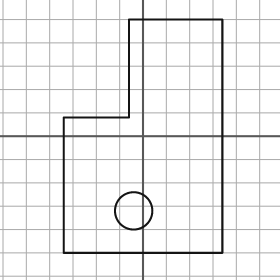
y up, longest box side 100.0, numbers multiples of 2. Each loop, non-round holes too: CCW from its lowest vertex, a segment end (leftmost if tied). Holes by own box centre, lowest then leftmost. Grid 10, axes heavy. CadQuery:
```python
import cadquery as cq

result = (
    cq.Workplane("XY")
    .moveTo(-34.0, -50.0)
    .lineTo(34.0, -50.0)
    .lineTo(34.0, 50.0)
    .lineTo(-6.0, 50.0)
    .lineTo(-6.0, 8.0)
    .lineTo(-34.0, 8.0)
    .close()
    .moveTo(-4.0, -32.0)
    .circle(8.0)
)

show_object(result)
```